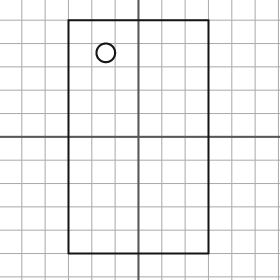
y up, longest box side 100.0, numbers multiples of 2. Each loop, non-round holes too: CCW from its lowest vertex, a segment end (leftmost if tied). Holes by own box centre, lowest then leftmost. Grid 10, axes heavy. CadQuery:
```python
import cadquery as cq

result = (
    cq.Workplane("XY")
    .moveTo(-30.0, -50.0)
    .lineTo(30.0, -50.0)
    .lineTo(30.0, 50.0)
    .lineTo(-30.0, 50.0)
    .close()
    .moveTo(-14.0, 36.0)
    .circle(4.0)
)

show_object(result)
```